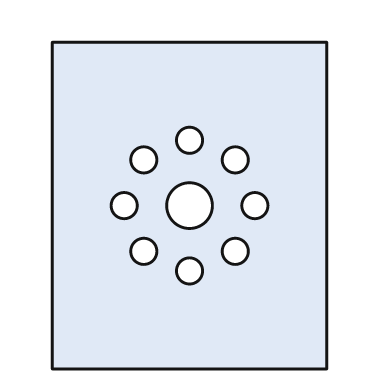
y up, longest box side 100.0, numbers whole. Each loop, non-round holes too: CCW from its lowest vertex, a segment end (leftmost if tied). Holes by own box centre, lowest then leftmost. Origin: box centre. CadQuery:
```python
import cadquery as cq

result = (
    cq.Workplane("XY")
    .moveTo(-42.0, -50.0)
    .lineTo(42.0, -50.0)
    .lineTo(42.0, 50.0)
    .lineTo(-42.0, 50.0)
    .close()
    .moveTo(0.0, -20.0)
    .circle(4.0)
    .moveTo(-14.0, -14.0)
    .circle(4.0)
    .moveTo(14.0, -14.0)
    .circle(4.0)
    .moveTo(-20.0, 0.0)
    .circle(4.0)
    .moveTo(0.0, 0.0)
    .circle(7.0)
    .moveTo(20.0, 0.0)
    .circle(4.0)
    .moveTo(-14.0, 14.0)
    .circle(4.0)
    .moveTo(14.0, 14.0)
    .circle(4.0)
    .moveTo(0.0, 20.0)
    .circle(4.0)
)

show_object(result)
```